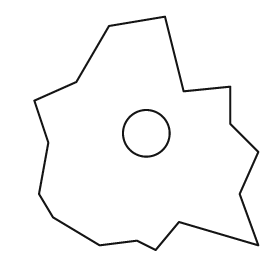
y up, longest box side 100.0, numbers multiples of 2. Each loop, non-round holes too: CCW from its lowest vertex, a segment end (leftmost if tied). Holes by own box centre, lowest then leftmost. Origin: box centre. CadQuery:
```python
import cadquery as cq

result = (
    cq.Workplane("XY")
    .moveTo(4.0, -50.0)
    .lineTo(14.0, -38.0)
    .lineTo(48.0, -48.0)
    .lineTo(40.0, -26.0)
    .lineTo(48.0, -8.0)
    .lineTo(36.0, 4.0)
    .lineTo(36.0, 20.0)
    .lineTo(16.0, 18.0)
    .lineTo(8.0, 50.0)
    .lineTo(-16.0, 46.0)
    .lineTo(-30.0, 22.0)
    .lineTo(-48.0, 14.0)
    .lineTo(-42.0, -4.0)
    .lineTo(-46.0, -26.0)
    .lineTo(-40.0, -36.0)
    .lineTo(-20.0, -48.0)
    .lineTo(-4.0, -46.0)
    .close()
    .moveTo(0.0, 0.0)
    .circle(10.0)
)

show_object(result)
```